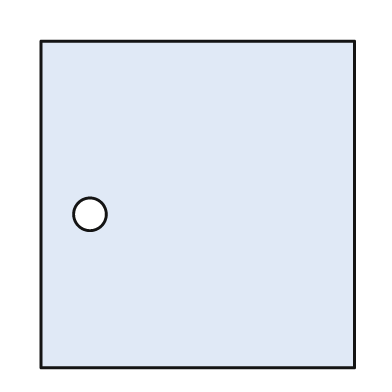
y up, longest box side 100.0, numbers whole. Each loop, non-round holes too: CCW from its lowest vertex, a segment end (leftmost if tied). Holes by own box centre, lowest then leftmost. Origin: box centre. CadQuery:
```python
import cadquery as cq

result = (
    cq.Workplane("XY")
    .moveTo(-48.0, -50.0)
    .lineTo(48.0, -50.0)
    .lineTo(48.0, 50.0)
    .lineTo(-48.0, 50.0)
    .close()
    .moveTo(-33.0, -3.0)
    .circle(5.0)
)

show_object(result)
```